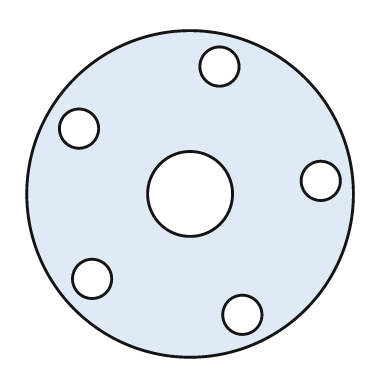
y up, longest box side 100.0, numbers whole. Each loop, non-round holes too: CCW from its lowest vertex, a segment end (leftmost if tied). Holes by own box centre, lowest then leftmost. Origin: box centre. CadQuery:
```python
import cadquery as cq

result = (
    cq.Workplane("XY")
    .moveTo(0.0, 0.0)
    .circle(50.0)
    .moveTo(16.0, -37.0)
    .circle(6.0)
    .moveTo(-30.0, -26.0)
    .circle(6.0)
    .moveTo(0.0, 0.0)
    .circle(13.0)
    .moveTo(40.0, 4.0)
    .circle(6.0)
    .moveTo(-34.0, 20.0)
    .circle(6.0)
    .moveTo(9.0, 39.0)
    .circle(6.0)
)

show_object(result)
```